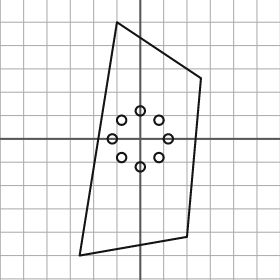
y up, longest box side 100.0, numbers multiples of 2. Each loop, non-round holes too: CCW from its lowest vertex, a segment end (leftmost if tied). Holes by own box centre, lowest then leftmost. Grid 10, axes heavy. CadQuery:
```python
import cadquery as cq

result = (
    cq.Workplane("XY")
    .moveTo(-26.0, -50.0)
    .lineTo(20.0, -42.0)
    .lineTo(26.0, 26.0)
    .lineTo(-10.0, 50.0)
    .close()
    .moveTo(0.0, -12.0)
    .circle(2.0)
    .moveTo(-8.0, -8.0)
    .circle(2.0)
    .moveTo(8.0, -8.0)
    .circle(2.0)
    .moveTo(-12.0, 0.0)
    .circle(2.0)
    .moveTo(12.0, 0.0)
    .circle(2.0)
    .moveTo(-8.0, 8.0)
    .circle(2.0)
    .moveTo(8.0, 8.0)
    .circle(2.0)
    .moveTo(0.0, 12.0)
    .circle(2.0)
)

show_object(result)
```